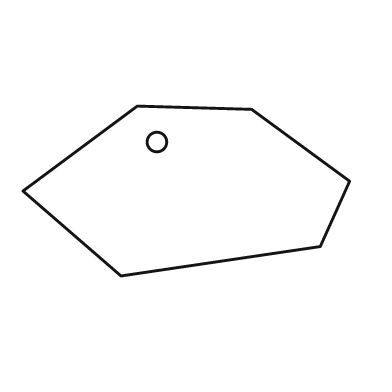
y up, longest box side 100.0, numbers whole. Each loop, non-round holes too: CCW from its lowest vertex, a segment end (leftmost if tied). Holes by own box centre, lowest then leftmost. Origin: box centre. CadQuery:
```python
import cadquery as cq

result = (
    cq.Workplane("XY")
    .moveTo(-20.0, -26.0)
    .lineTo(41.0, -17.0)
    .lineTo(50.0, 3.0)
    .lineTo(20.0, 25.0)
    .lineTo(-15.0, 26.0)
    .lineTo(-50.0, 0.0)
    .close()
    .moveTo(-9.0, 15.0)
    .circle(3.0)
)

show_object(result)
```